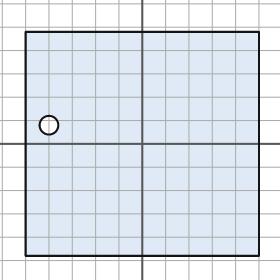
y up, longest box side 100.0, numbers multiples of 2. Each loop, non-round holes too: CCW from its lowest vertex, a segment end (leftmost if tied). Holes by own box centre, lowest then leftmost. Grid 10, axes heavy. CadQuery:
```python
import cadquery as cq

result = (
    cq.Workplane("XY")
    .moveTo(-50.0, -48.0)
    .lineTo(50.0, -48.0)
    .lineTo(50.0, 48.0)
    .lineTo(-50.0, 48.0)
    .close()
    .moveTo(-40.0, 8.0)
    .circle(4.0)
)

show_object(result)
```